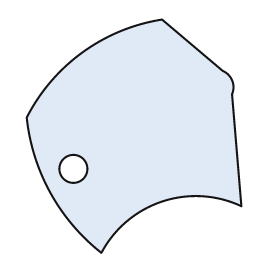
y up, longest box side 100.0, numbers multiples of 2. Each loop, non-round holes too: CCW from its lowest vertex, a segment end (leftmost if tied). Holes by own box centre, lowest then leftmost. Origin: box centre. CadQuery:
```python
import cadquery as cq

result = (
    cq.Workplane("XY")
    .moveTo(-14.0, -50.0)
    .threePointArc((12.0, -28.0), (46.0, -30.0))
    .lineTo(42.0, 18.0)
    .threePointArc((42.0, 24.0), (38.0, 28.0))
    .lineTo(12.0, 50.0)
    .threePointArc((-22.0, 36.0), (-46.0, 8.0))
    .threePointArc((-36.0, -24.0), (-14.0, -50.0))
    .close()
    .moveTo(-26.0, -14.0)
    .circle(6.0)
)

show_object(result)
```